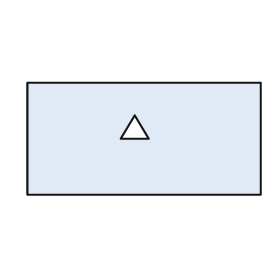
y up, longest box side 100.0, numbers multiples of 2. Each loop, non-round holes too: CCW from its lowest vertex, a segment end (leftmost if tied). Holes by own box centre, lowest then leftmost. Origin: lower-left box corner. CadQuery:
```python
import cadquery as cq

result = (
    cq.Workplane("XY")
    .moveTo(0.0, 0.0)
    .lineTo(100.0, 0.0)
    .lineTo(100.0, 48.0)
    .lineTo(0.0, 48.0)
    .close()
    .moveTo(40.0, 24.0)
    .lineTo(52.0, 24.0)
    .lineTo(46.0, 34.0)
    .close()
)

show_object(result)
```